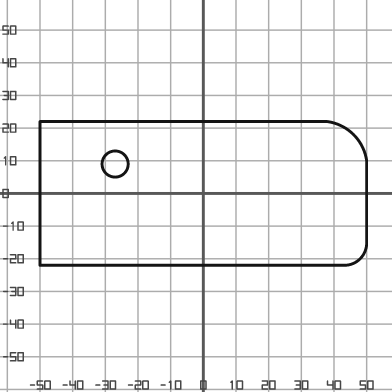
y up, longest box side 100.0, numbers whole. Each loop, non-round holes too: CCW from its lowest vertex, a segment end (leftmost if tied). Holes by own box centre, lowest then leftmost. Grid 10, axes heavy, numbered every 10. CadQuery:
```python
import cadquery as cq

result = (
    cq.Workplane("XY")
    .moveTo(-50.0, -22.0)
    .lineTo(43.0, -22.0)
    .threePointArc((48.0, -20.0), (50.0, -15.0))
    .lineTo(50.0, 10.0)
    .threePointArc((46.0, 18.0), (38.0, 22.0))
    .lineTo(-50.0, 22.0)
    .close()
    .moveTo(-27.0, 9.0)
    .circle(4.0)
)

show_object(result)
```